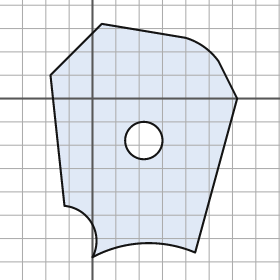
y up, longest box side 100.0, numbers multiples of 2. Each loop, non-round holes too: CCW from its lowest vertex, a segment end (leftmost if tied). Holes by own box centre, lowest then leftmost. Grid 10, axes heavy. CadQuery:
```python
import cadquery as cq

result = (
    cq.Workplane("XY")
    .moveTo(0.0, -68.0)
    .threePointArc((22.0, -62.0), (44.0, -66.0))
    .lineTo(62.0, 0.0)
    .lineTo(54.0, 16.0)
    .threePointArc((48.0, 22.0), (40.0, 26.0))
    .lineTo(4.0, 32.0)
    .lineTo(-18.0, 10.0)
    .lineTo(-12.0, -46.0)
    .threePointArc((0.0, -54.0), (0.0, -68.0))
    .close()
    .moveTo(22.0, -18.0)
    .circle(8.0)
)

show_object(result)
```